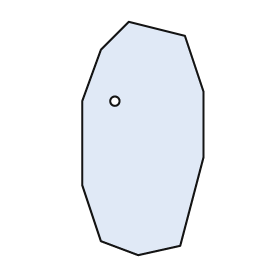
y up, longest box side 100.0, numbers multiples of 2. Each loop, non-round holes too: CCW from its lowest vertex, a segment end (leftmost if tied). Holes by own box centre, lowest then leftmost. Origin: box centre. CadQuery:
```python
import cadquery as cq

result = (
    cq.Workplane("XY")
    .moveTo(-2.0, -50.0)
    .lineTo(16.0, -46.0)
    .lineTo(26.0, -8.0)
    .lineTo(26.0, 20.0)
    .lineTo(18.0, 44.0)
    .lineTo(-6.0, 50.0)
    .lineTo(-18.0, 38.0)
    .lineTo(-26.0, 16.0)
    .lineTo(-26.0, -20.0)
    .lineTo(-18.0, -44.0)
    .close()
    .moveTo(-12.0, 16.0)
    .circle(2.0)
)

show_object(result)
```